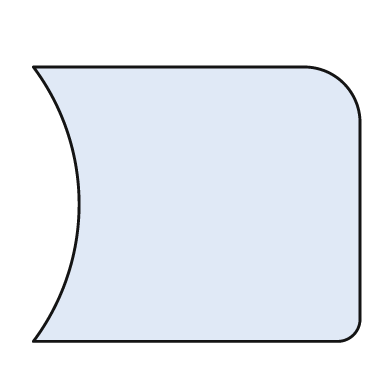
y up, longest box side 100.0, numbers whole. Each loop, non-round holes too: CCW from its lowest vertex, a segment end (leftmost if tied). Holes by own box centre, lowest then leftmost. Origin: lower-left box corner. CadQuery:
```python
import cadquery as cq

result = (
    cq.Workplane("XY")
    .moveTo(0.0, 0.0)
    .lineTo(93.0, 0.0)
    .threePointArc((98.0, 2.0), (100.0, 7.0))
    .lineTo(100.0, 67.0)
    .threePointArc((95.0, 79.0), (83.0, 84.0))
    .lineTo(0.0, 84.0)
    .threePointArc((14.0, 42.0), (0.0, 0.0))
    .close()
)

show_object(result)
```